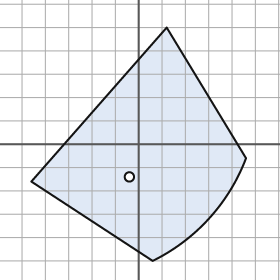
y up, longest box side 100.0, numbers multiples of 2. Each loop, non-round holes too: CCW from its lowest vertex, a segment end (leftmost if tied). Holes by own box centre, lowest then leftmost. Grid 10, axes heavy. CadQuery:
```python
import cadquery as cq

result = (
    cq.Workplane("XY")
    .moveTo(6.0, -50.0)
    .threePointArc((30.0, -32.0), (46.0, -6.0))
    .lineTo(12.0, 50.0)
    .lineTo(-46.0, -16.0)
    .close()
    .moveTo(-4.0, -14.0)
    .circle(2.0)
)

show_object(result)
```